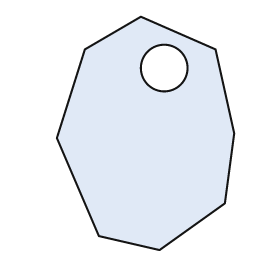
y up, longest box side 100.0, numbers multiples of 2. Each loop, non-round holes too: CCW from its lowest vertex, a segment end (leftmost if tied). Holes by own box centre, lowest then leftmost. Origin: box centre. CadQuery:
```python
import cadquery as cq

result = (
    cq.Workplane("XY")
    .moveTo(6.0, -50.0)
    .lineTo(34.0, -30.0)
    .lineTo(38.0, 0.0)
    .lineTo(30.0, 36.0)
    .lineTo(-2.0, 50.0)
    .lineTo(-26.0, 36.0)
    .lineTo(-38.0, -2.0)
    .lineTo(-20.0, -44.0)
    .close()
    .moveTo(8.0, 28.0)
    .circle(10.0)
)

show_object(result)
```